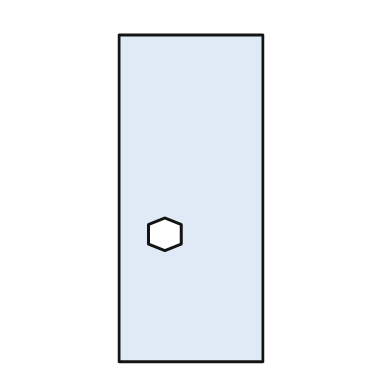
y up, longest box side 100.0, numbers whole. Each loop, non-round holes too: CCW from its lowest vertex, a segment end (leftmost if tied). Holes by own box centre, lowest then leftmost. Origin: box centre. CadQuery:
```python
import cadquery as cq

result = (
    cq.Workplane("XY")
    .moveTo(-22.0, -50.0)
    .lineTo(22.0, -50.0)
    .lineTo(22.0, 50.0)
    .lineTo(-22.0, 50.0)
    .close()
    .moveTo(-8.0, -16.0)
    .lineTo(-3.0, -14.0)
    .lineTo(-3.0, -8.0)
    .lineTo(-8.0, -6.0)
    .lineTo(-13.0, -8.0)
    .lineTo(-13.0, -14.0)
    .close()
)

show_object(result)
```